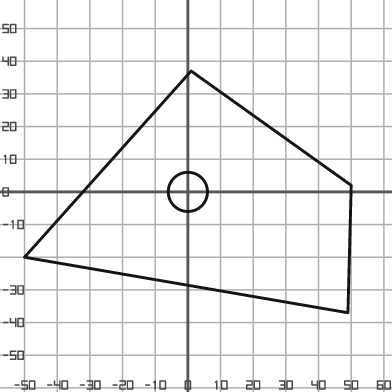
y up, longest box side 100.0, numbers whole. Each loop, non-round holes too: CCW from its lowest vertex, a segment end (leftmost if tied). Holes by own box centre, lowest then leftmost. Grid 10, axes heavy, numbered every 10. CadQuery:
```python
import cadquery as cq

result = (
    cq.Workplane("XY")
    .moveTo(49.0, -37.0)
    .lineTo(50.0, 2.0)
    .lineTo(1.0, 37.0)
    .lineTo(-50.0, -20.0)
    .close()
    .moveTo(0.0, 0.0)
    .circle(6.0)
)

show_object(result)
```